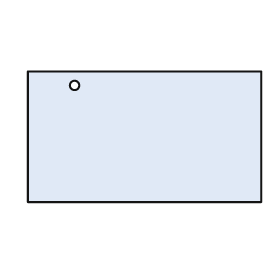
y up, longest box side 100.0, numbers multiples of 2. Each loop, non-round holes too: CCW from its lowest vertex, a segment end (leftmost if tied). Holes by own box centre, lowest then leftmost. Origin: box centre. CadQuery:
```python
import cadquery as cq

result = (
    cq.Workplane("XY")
    .moveTo(-50.0, -28.0)
    .lineTo(50.0, -28.0)
    .lineTo(50.0, 28.0)
    .lineTo(-50.0, 28.0)
    .close()
    .moveTo(-30.0, 22.0)
    .circle(2.0)
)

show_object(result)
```